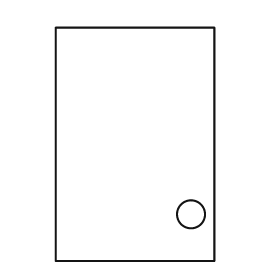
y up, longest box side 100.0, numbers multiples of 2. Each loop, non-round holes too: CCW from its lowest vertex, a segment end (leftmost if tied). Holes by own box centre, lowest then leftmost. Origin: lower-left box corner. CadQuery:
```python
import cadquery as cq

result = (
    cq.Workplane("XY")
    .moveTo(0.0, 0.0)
    .lineTo(68.0, 0.0)
    .lineTo(68.0, 100.0)
    .lineTo(0.0, 100.0)
    .close()
    .moveTo(58.0, 20.0)
    .circle(6.0)
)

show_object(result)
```